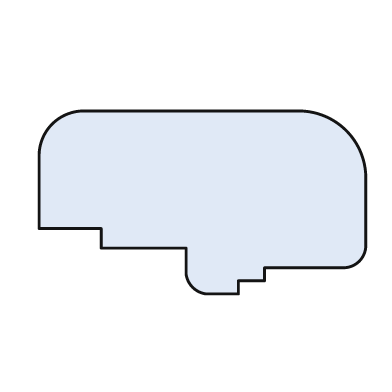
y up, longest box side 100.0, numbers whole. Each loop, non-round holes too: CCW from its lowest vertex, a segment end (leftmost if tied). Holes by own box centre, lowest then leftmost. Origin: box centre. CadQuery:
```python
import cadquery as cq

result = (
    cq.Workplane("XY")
    .moveTo(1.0, -28.0)
    .lineTo(11.0, -28.0)
    .lineTo(11.0, -24.0)
    .lineTo(19.0, -24.0)
    .lineTo(19.0, -20.0)
    .lineTo(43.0, -20.0)
    .threePointArc((48.0, -18.0), (50.0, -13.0))
    .lineTo(50.0, 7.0)
    .threePointArc((44.0, 22.0), (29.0, 28.0))
    .lineTo(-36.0, 28.0)
    .threePointArc((-46.0, 24.0), (-50.0, 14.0))
    .lineTo(-50.0, -8.0)
    .lineTo(-31.0, -8.0)
    .lineTo(-31.0, -14.0)
    .lineTo(-5.0, -14.0)
    .lineTo(-5.0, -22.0)
    .threePointArc((-3.0, -26.0), (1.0, -28.0))
    .close()
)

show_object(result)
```